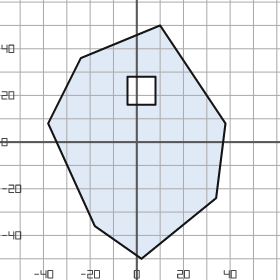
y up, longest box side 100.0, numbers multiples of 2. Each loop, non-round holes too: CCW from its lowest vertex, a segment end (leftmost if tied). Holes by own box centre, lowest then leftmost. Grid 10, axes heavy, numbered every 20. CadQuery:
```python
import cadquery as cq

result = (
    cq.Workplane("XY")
    .moveTo(2.0, -50.0)
    .lineTo(34.0, -24.0)
    .lineTo(38.0, 8.0)
    .lineTo(10.0, 50.0)
    .lineTo(-24.0, 36.0)
    .lineTo(-38.0, 8.0)
    .lineTo(-18.0, -36.0)
    .close()
    .moveTo(-4.0, 16.0)
    .lineTo(8.0, 16.0)
    .lineTo(8.0, 28.0)
    .lineTo(-4.0, 28.0)
    .close()
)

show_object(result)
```